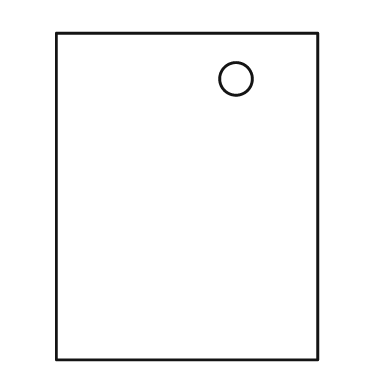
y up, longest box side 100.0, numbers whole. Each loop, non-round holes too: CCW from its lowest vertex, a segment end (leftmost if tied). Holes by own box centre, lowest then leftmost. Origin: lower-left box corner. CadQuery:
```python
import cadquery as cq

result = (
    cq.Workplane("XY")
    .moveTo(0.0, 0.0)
    .lineTo(80.0, 0.0)
    .lineTo(80.0, 100.0)
    .lineTo(0.0, 100.0)
    .close()
    .moveTo(55.0, 86.0)
    .circle(5.0)
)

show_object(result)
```